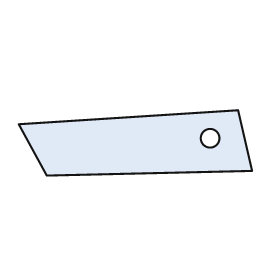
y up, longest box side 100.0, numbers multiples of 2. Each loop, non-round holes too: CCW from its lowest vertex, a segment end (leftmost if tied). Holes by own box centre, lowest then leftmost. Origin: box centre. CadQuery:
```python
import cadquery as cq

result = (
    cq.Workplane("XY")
    .moveTo(-38.0, -14.0)
    .lineTo(50.0, -12.0)
    .lineTo(44.0, 14.0)
    .lineTo(-50.0, 8.0)
    .close()
    .moveTo(32.0, 2.0)
    .circle(4.0)
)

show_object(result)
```